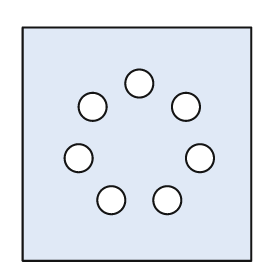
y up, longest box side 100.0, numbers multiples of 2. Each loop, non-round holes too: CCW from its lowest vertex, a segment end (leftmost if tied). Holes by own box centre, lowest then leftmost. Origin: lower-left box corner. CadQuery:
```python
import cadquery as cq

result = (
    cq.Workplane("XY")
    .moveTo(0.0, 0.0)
    .lineTo(98.0, 0.0)
    .lineTo(98.0, 100.0)
    .lineTo(0.0, 100.0)
    .close()
    .moveTo(38.0, 26.0)
    .circle(6.0)
    .moveTo(62.0, 26.0)
    .circle(6.0)
    .moveTo(24.0, 44.0)
    .circle(6.0)
    .moveTo(76.0, 44.0)
    .circle(6.0)
    .moveTo(30.0, 66.0)
    .circle(6.0)
    .moveTo(70.0, 66.0)
    .circle(6.0)
    .moveTo(50.0, 76.0)
    .circle(6.0)
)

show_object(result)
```